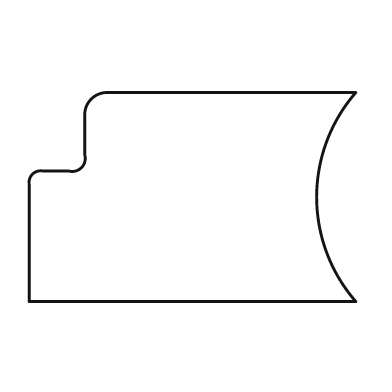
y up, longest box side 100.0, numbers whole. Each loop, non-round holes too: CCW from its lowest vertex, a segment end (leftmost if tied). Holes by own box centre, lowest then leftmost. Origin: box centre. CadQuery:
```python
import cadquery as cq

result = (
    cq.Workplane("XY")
    .moveTo(-50.0, -32.0)
    .lineTo(50.0, -32.0)
    .threePointArc((38.0, 0.0), (50.0, 32.0))
    .lineTo(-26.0, 32.0)
    .threePointArc((-31.0, 30.0), (-33.0, 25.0))
    .lineTo(-33.0, 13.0)
    .threePointArc((-34.0, 9.0), (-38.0, 8.0))
    .lineTo(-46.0, 8.0)
    .threePointArc((-49.0, 7.0), (-50.0, 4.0))
    .close()
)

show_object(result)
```